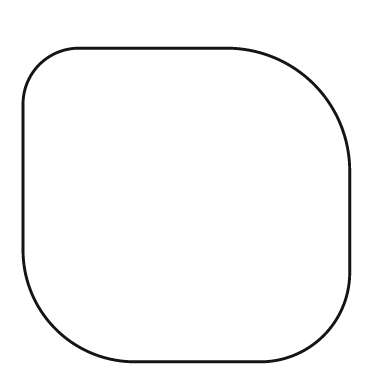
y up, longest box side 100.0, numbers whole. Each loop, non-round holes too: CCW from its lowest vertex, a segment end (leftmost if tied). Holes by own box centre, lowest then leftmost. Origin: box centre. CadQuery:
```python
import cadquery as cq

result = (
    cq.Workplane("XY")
    .moveTo(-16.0, -48.0)
    .lineTo(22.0, -48.0)
    .threePointArc((42.0, -40.0), (50.0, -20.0))
    .lineTo(50.0, 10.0)
    .threePointArc((39.0, 37.0), (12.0, 48.0))
    .lineTo(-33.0, 48.0)
    .threePointArc((-45.0, 43.0), (-50.0, 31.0))
    .lineTo(-50.0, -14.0)
    .threePointArc((-40.0, -38.0), (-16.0, -48.0))
    .close()
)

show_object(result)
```